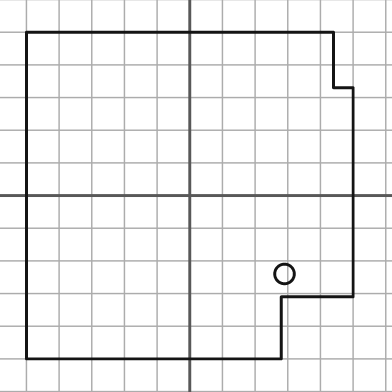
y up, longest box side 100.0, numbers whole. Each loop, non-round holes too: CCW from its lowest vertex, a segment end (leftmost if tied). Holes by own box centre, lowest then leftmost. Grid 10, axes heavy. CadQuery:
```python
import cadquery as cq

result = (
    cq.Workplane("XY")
    .moveTo(-50.0, -50.0)
    .lineTo(28.0, -50.0)
    .lineTo(28.0, -31.0)
    .lineTo(50.0, -31.0)
    .lineTo(50.0, 33.0)
    .lineTo(44.0, 33.0)
    .lineTo(44.0, 50.0)
    .lineTo(-50.0, 50.0)
    .close()
    .moveTo(29.0, -24.0)
    .circle(3.0)
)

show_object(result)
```